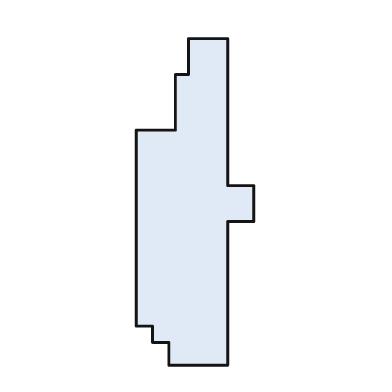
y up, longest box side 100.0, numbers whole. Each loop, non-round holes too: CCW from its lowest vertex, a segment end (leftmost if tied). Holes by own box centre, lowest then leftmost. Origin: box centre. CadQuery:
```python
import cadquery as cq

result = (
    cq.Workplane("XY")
    .moveTo(-8.0, -50.0)
    .lineTo(10.0, -50.0)
    .lineTo(10.0, -6.0)
    .lineTo(18.0, -6.0)
    .lineTo(18.0, 5.0)
    .lineTo(10.0, 5.0)
    .lineTo(10.0, 50.0)
    .lineTo(-2.0, 50.0)
    .lineTo(-2.0, 39.0)
    .lineTo(-6.0, 39.0)
    .lineTo(-6.0, 22.0)
    .lineTo(-18.0, 22.0)
    .lineTo(-18.0, -38.0)
    .lineTo(-13.0, -38.0)
    .lineTo(-13.0, -43.0)
    .lineTo(-8.0, -43.0)
    .close()
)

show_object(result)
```